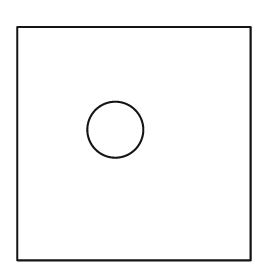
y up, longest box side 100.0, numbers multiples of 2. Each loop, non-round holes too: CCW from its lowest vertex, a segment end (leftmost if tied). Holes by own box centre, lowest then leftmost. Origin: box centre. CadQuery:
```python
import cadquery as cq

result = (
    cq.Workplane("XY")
    .moveTo(-50.0, -50.0)
    .lineTo(50.0, -50.0)
    .lineTo(50.0, 50.0)
    .lineTo(-50.0, 50.0)
    .close()
    .moveTo(-8.0, 6.0)
    .circle(12.0)
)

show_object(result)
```